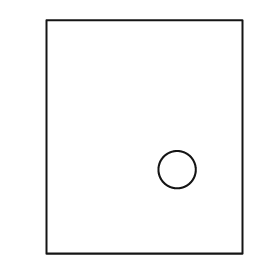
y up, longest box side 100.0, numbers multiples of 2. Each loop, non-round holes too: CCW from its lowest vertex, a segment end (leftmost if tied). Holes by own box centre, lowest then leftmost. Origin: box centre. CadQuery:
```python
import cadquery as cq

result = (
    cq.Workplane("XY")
    .moveTo(-42.0, -50.0)
    .lineTo(42.0, -50.0)
    .lineTo(42.0, 50.0)
    .lineTo(-42.0, 50.0)
    .close()
    .moveTo(14.0, -14.0)
    .circle(8.0)
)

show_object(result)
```